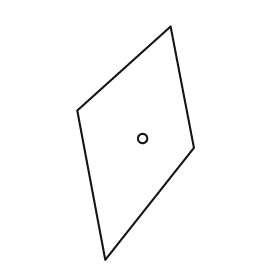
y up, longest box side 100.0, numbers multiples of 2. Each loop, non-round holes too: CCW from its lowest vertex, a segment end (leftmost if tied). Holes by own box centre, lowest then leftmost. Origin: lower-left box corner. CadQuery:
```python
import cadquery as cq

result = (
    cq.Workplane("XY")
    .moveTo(12.0, 0.0)
    .lineTo(50.0, 48.0)
    .lineTo(40.0, 100.0)
    .lineTo(0.0, 64.0)
    .close()
    .moveTo(28.0, 52.0)
    .circle(2.0)
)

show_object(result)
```